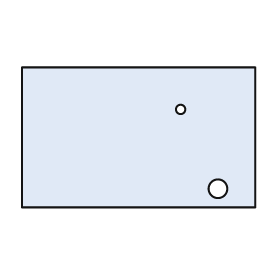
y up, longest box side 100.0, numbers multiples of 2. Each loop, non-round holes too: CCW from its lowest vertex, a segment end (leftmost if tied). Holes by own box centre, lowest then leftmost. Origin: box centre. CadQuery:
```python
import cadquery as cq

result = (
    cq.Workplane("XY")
    .moveTo(-50.0, -30.0)
    .lineTo(50.0, -30.0)
    .lineTo(50.0, 30.0)
    .lineTo(-50.0, 30.0)
    .close()
    .moveTo(34.0, -22.0)
    .circle(4.0)
    .moveTo(18.0, 12.0)
    .circle(2.0)
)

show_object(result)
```